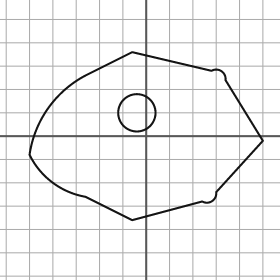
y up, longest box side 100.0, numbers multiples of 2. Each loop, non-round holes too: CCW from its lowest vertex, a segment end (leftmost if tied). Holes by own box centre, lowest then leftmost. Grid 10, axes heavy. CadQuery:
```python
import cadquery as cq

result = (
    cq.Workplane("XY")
    .moveTo(-6.0, -36.0)
    .lineTo(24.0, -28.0)
    .threePointArc((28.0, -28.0), (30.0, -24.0))
    .lineTo(50.0, -2.0)
    .lineTo(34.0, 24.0)
    .threePointArc((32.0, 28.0), (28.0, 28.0))
    .lineTo(-6.0, 36.0)
    .lineTo(-26.0, 26.0)
    .threePointArc((-42.0, 12.0), (-50.0, -8.0))
    .threePointArc((-40.0, -20.0), (-26.0, -26.0))
    .close()
    .moveTo(-4.0, 10.0)
    .circle(8.0)
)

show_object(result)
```